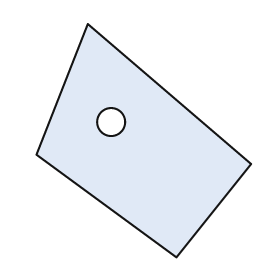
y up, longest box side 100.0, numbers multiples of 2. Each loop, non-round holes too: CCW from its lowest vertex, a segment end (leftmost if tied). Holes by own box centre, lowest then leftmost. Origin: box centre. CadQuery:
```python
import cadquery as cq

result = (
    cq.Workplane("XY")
    .moveTo(14.0, -50.0)
    .lineTo(46.0, -10.0)
    .lineTo(-24.0, 50.0)
    .lineTo(-46.0, -6.0)
    .close()
    .moveTo(-14.0, 8.0)
    .circle(6.0)
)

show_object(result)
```